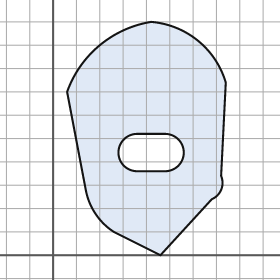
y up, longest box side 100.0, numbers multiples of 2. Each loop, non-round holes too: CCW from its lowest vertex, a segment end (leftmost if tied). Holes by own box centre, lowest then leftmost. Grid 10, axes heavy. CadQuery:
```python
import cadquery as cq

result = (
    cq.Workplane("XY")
    .moveTo(46.0, 0.0)
    .lineTo(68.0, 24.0)
    .threePointArc((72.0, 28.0), (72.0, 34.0))
    .lineTo(74.0, 74.0)
    .threePointArc((62.0, 92.0), (42.0, 100.0))
    .threePointArc((20.0, 90.0), (6.0, 70.0))
    .lineTo(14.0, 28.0)
    .threePointArc((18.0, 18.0), (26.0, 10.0))
    .close()
    .moveTo(36.0, 36.0)
    .lineTo(48.0, 36.0)
    .threePointArc((56.0, 44.0), (48.0, 52.0))
    .lineTo(36.0, 52.0)
    .threePointArc((28.0, 44.0), (36.0, 36.0))
    .close()
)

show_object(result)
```